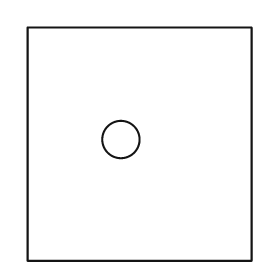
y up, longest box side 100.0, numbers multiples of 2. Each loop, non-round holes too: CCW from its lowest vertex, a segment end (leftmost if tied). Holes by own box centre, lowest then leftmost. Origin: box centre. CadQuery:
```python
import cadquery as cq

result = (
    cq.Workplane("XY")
    .moveTo(-48.0, -50.0)
    .lineTo(48.0, -50.0)
    .lineTo(48.0, 50.0)
    .lineTo(-48.0, 50.0)
    .close()
    .moveTo(-8.0, 2.0)
    .circle(8.0)
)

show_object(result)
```